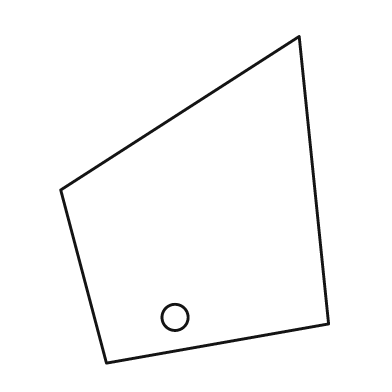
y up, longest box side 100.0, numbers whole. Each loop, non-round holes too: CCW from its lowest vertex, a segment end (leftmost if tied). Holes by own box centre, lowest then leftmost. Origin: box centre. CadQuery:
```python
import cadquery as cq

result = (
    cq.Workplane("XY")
    .moveTo(-27.0, -50.0)
    .lineTo(41.0, -38.0)
    .lineTo(32.0, 50.0)
    .lineTo(-41.0, 3.0)
    .close()
    .moveTo(-6.0, -36.0)
    .circle(4.0)
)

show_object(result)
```